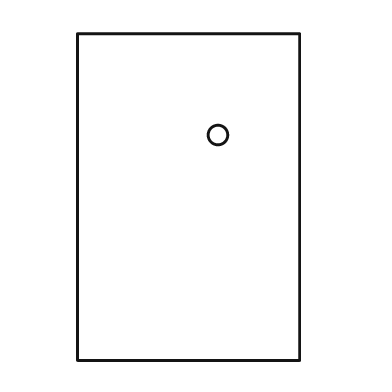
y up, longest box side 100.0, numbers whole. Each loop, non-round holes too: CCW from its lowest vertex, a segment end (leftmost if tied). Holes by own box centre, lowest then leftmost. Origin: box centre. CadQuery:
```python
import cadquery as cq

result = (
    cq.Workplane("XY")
    .moveTo(-34.0, -50.0)
    .lineTo(34.0, -50.0)
    .lineTo(34.0, 50.0)
    .lineTo(-34.0, 50.0)
    .close()
    .moveTo(9.0, 19.0)
    .circle(3.0)
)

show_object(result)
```